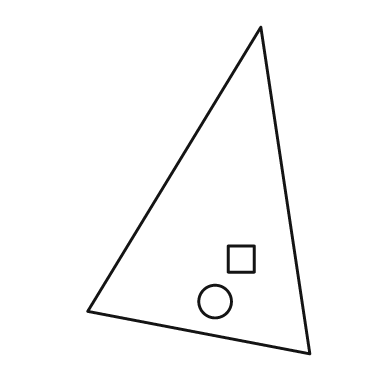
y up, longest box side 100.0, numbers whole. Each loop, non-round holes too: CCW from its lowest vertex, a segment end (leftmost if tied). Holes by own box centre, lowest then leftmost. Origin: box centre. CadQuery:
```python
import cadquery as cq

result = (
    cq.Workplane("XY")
    .moveTo(34.0, -50.0)
    .lineTo(19.0, 50.0)
    .lineTo(-34.0, -37.0)
    .close()
    .moveTo(5.0, -34.0)
    .circle(5.0)
    .moveTo(9.0, -25.0)
    .lineTo(17.0, -25.0)
    .lineTo(17.0, -17.0)
    .lineTo(9.0, -17.0)
    .close()
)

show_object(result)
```